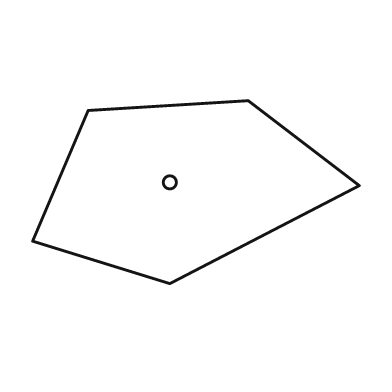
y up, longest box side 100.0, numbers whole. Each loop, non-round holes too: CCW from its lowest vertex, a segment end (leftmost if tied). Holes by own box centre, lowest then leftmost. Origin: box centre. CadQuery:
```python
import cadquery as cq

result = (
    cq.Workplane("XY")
    .moveTo(-8.0, -28.0)
    .lineTo(50.0, 2.0)
    .lineTo(16.0, 28.0)
    .lineTo(-33.0, 25.0)
    .lineTo(-50.0, -15.0)
    .close()
    .moveTo(-8.0, 3.0)
    .circle(2.0)
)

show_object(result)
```